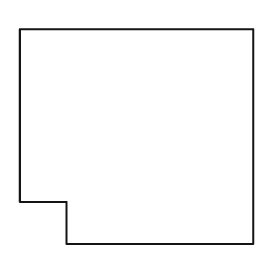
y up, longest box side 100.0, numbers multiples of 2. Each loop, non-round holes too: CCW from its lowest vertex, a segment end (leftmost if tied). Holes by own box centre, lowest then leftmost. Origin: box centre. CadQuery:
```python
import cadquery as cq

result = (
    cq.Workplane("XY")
    .moveTo(-30.0, -46.0)
    .lineTo(50.0, -46.0)
    .lineTo(50.0, 46.0)
    .lineTo(-50.0, 46.0)
    .lineTo(-50.0, -28.0)
    .lineTo(-30.0, -28.0)
    .close()
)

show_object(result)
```